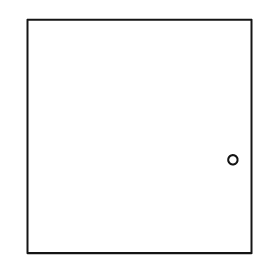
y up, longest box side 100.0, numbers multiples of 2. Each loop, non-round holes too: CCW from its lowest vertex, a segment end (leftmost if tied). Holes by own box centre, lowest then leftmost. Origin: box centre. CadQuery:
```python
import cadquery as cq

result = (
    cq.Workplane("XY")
    .moveTo(-48.0, -50.0)
    .lineTo(48.0, -50.0)
    .lineTo(48.0, 50.0)
    .lineTo(-48.0, 50.0)
    .close()
    .moveTo(40.0, -10.0)
    .circle(2.0)
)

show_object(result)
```